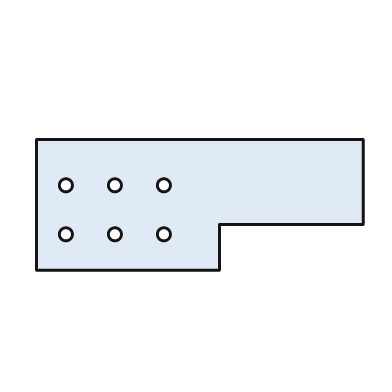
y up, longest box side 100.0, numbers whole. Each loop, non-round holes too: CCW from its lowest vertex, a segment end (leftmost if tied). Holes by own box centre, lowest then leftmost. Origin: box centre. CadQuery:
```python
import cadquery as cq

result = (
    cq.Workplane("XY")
    .moveTo(-50.0, -20.0)
    .lineTo(6.0, -20.0)
    .lineTo(6.0, -6.0)
    .lineTo(50.0, -6.0)
    .lineTo(50.0, 20.0)
    .lineTo(-50.0, 20.0)
    .close()
    .moveTo(-41.0, -9.0)
    .circle(2.0)
    .moveTo(-26.0, -9.0)
    .circle(2.0)
    .moveTo(-11.0, -9.0)
    .circle(2.0)
    .moveTo(-41.0, 6.0)
    .circle(2.0)
    .moveTo(-26.0, 6.0)
    .circle(2.0)
    .moveTo(-11.0, 6.0)
    .circle(2.0)
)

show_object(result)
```